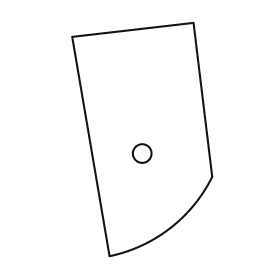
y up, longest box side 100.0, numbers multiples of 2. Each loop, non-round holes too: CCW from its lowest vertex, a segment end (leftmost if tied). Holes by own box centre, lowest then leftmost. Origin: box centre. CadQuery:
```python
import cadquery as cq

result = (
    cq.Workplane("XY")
    .moveTo(-14.0, -50.0)
    .threePointArc((12.0, -38.0), (30.0, -16.0))
    .lineTo(22.0, 50.0)
    .lineTo(-30.0, 44.0)
    .close()
    .moveTo(0.0, -6.0)
    .circle(4.0)
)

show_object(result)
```